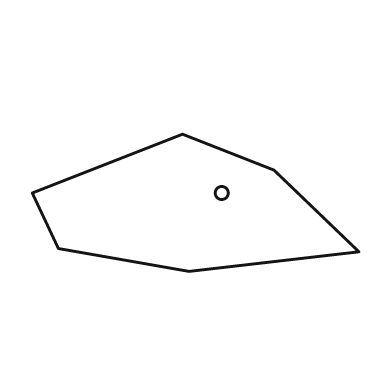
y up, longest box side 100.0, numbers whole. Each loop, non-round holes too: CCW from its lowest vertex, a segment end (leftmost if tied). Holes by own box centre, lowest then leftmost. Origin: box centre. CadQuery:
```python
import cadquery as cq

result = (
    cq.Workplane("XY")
    .moveTo(-2.0, -21.0)
    .lineTo(50.0, -15.0)
    .lineTo(24.0, 10.0)
    .lineTo(-4.0, 21.0)
    .lineTo(-50.0, 3.0)
    .lineTo(-42.0, -14.0)
    .close()
    .moveTo(8.0, 3.0)
    .circle(2.0)
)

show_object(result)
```